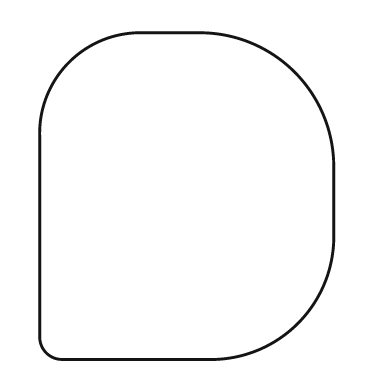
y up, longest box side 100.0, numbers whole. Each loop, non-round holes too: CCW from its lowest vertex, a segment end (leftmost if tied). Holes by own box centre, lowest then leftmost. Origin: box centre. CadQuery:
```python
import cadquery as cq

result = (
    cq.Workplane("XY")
    .moveTo(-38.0, -50.0)
    .lineTo(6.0, -50.0)
    .threePointArc((34.0, -39.0), (45.0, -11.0))
    .lineTo(45.0, 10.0)
    .threePointArc((33.0, 38.0), (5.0, 50.0))
    .lineTo(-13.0, 50.0)
    .threePointArc((-36.0, 41.0), (-45.0, 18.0))
    .lineTo(-45.0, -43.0)
    .threePointArc((-43.0, -48.0), (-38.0, -50.0))
    .close()
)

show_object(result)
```